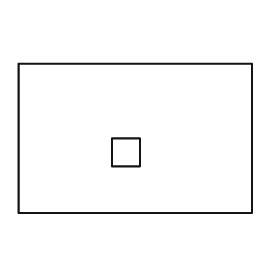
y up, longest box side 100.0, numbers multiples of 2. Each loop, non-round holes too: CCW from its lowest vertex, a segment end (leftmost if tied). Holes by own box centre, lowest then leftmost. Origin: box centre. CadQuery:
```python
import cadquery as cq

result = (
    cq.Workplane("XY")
    .moveTo(-50.0, -32.0)
    .lineTo(50.0, -32.0)
    .lineTo(50.0, 32.0)
    .lineTo(-50.0, 32.0)
    .close()
    .moveTo(-10.0, -12.0)
    .lineTo(2.0, -12.0)
    .lineTo(2.0, 0.0)
    .lineTo(-10.0, 0.0)
    .close()
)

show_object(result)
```